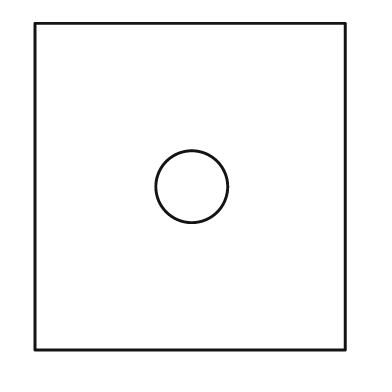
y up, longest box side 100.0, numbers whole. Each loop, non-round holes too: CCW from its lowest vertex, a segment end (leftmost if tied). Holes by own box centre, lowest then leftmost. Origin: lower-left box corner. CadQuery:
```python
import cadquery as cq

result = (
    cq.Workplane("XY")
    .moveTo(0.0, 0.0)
    .lineTo(95.0, 0.0)
    .lineTo(95.0, 100.0)
    .lineTo(0.0, 100.0)
    .close()
    .moveTo(48.0, 50.0)
    .circle(11.0)
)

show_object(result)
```